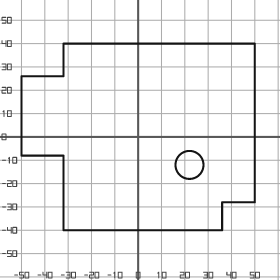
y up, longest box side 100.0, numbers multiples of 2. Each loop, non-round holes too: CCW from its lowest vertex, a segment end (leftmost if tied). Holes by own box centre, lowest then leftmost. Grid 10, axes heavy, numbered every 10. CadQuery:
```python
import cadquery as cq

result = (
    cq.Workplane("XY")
    .moveTo(-32.0, -40.0)
    .lineTo(36.0, -40.0)
    .lineTo(36.0, -28.0)
    .lineTo(50.0, -28.0)
    .lineTo(50.0, 40.0)
    .lineTo(-32.0, 40.0)
    .lineTo(-32.0, 26.0)
    .lineTo(-50.0, 26.0)
    .lineTo(-50.0, -8.0)
    .lineTo(-32.0, -8.0)
    .close()
    .moveTo(22.0, -12.0)
    .circle(6.0)
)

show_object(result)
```